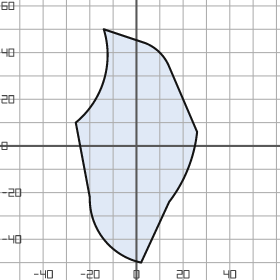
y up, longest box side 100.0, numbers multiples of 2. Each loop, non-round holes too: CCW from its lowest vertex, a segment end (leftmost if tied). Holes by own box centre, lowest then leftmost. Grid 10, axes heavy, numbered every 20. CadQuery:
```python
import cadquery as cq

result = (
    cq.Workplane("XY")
    .moveTo(2.0, -50.0)
    .lineTo(14.0, -24.0)
    .threePointArc((22.0, -10.0), (26.0, 6.0))
    .lineTo(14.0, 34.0)
    .threePointArc((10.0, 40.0), (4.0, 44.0))
    .lineTo(-14.0, 50.0)
    .threePointArc((-14.0, 28.0), (-26.0, 10.0))
    .lineTo(-20.0, -22.0)
    .threePointArc((-14.0, -40.0), (2.0, -50.0))
    .close()
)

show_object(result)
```